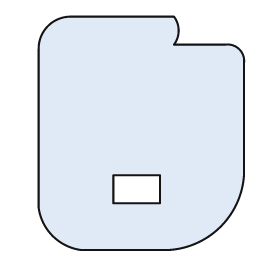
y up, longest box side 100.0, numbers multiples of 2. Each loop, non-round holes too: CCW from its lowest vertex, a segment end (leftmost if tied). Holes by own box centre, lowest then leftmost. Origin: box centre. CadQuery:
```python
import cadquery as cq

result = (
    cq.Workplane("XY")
    .moveTo(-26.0, -50.0)
    .lineTo(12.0, -50.0)
    .threePointArc((34.0, -40.0), (44.0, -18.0))
    .lineTo(44.0, 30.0)
    .threePointArc((42.0, 36.0), (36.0, 38.0))
    .lineTo(14.0, 38.0)
    .threePointArc((16.0, 44.0), (14.0, 50.0))
    .lineTo(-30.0, 50.0)
    .threePointArc((-40.0, 46.0), (-44.0, 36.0))
    .lineTo(-44.0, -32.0)
    .threePointArc((-38.0, -44.0), (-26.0, -50.0))
    .close()
    .moveTo(-12.0, -30.0)
    .lineTo(8.0, -30.0)
    .lineTo(8.0, -18.0)
    .lineTo(-12.0, -18.0)
    .close()
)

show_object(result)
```